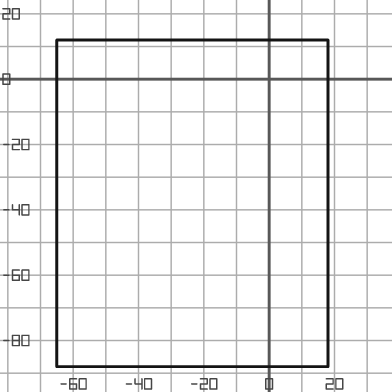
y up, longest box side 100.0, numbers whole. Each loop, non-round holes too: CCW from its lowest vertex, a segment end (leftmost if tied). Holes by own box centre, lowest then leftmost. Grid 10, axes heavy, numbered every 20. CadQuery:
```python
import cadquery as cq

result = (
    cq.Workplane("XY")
    .moveTo(-65.0, -88.0)
    .lineTo(18.0, -88.0)
    .lineTo(18.0, 12.0)
    .lineTo(-65.0, 12.0)
    .close()
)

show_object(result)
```